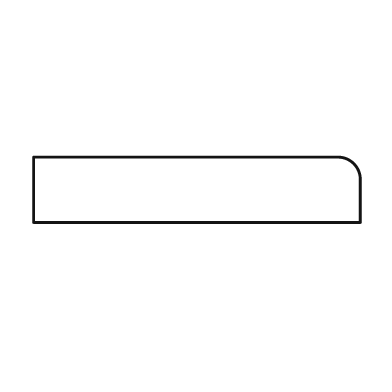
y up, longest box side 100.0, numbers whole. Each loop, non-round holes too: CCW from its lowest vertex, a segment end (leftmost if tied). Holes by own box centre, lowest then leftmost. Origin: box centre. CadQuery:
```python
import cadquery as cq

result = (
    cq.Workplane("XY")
    .moveTo(-50.0, -10.0)
    .lineTo(50.0, -10.0)
    .lineTo(50.0, 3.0)
    .threePointArc((48.0, 8.0), (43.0, 10.0))
    .lineTo(-50.0, 10.0)
    .close()
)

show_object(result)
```